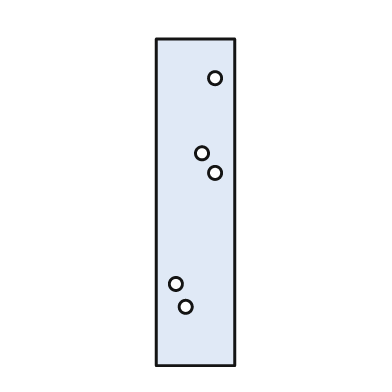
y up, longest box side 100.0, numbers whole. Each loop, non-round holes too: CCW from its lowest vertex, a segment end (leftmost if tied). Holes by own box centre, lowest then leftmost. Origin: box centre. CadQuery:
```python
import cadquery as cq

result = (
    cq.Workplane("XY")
    .moveTo(-12.0, -50.0)
    .lineTo(12.0, -50.0)
    .lineTo(12.0, 50.0)
    .lineTo(-12.0, 50.0)
    .close()
    .moveTo(-3.0, -32.0)
    .circle(2.0)
    .moveTo(-6.0, -25.0)
    .circle(2.0)
    .moveTo(6.0, 9.0)
    .circle(2.0)
    .moveTo(2.0, 15.0)
    .circle(2.0)
    .moveTo(6.0, 38.0)
    .circle(2.0)
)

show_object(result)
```